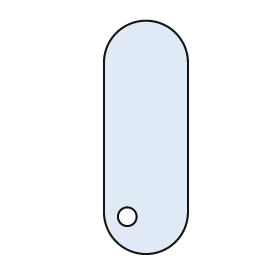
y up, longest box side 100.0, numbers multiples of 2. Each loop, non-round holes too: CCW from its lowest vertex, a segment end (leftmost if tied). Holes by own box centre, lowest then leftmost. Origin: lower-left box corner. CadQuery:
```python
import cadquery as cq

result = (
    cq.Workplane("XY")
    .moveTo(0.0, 18.0)
    .threePointArc((18.0, 0.0), (36.0, 18.0))
    .lineTo(36.0, 82.0)
    .threePointArc((18.0, 100.0), (0.0, 82.0))
    .close()
    .moveTo(10.0, 16.0)
    .circle(4.0)
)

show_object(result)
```